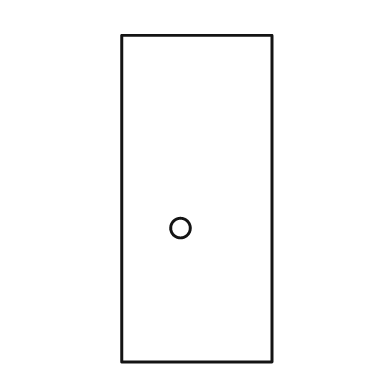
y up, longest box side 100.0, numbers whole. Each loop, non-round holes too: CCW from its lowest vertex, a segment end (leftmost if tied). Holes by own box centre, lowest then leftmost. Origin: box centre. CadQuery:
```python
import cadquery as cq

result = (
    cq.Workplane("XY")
    .moveTo(-23.0, -50.0)
    .lineTo(23.0, -50.0)
    .lineTo(23.0, 50.0)
    .lineTo(-23.0, 50.0)
    .close()
    .moveTo(-5.0, -9.0)
    .circle(3.0)
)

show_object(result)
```